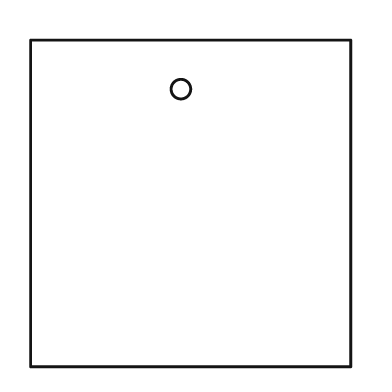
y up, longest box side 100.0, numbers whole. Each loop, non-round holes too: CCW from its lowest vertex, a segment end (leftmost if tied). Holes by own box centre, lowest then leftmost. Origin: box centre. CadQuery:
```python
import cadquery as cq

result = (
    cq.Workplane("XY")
    .moveTo(-49.0, -50.0)
    .lineTo(49.0, -50.0)
    .lineTo(49.0, 50.0)
    .lineTo(-49.0, 50.0)
    .close()
    .moveTo(-3.0, 35.0)
    .circle(3.0)
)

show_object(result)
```